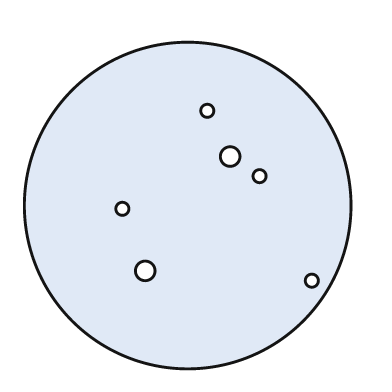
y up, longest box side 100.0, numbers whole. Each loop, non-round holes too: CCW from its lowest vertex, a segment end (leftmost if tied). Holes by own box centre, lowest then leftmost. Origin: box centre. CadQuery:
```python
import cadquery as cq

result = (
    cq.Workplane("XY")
    .moveTo(0.0, 0.0)
    .circle(50.0)
    .moveTo(38.0, -23.0)
    .circle(2.0)
    .moveTo(-13.0, -20.0)
    .circle(3.0)
    .moveTo(-20.0, -1.0)
    .circle(2.0)
    .moveTo(22.0, 9.0)
    .circle(2.0)
    .moveTo(13.0, 15.0)
    .circle(3.0)
    .moveTo(6.0, 29.0)
    .circle(2.0)
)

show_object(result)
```